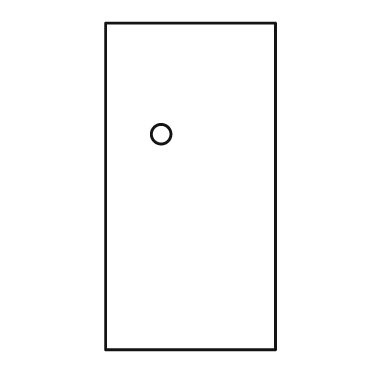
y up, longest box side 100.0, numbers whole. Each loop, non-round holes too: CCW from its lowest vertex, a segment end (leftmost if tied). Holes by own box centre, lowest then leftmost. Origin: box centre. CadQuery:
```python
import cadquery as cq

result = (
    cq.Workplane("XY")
    .moveTo(-26.0, -50.0)
    .lineTo(26.0, -50.0)
    .lineTo(26.0, 50.0)
    .lineTo(-26.0, 50.0)
    .close()
    .moveTo(-9.0, 16.0)
    .circle(3.0)
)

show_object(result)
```